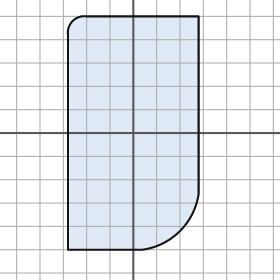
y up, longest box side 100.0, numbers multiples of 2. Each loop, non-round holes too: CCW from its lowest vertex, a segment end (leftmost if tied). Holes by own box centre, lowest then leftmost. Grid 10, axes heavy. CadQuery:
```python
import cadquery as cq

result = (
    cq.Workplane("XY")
    .moveTo(-28.0, -50.0)
    .lineTo(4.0, -50.0)
    .threePointArc((20.0, -42.0), (28.0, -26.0))
    .lineTo(28.0, 50.0)
    .lineTo(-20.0, 50.0)
    .threePointArc((-26.0, 48.0), (-28.0, 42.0))
    .close()
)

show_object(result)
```